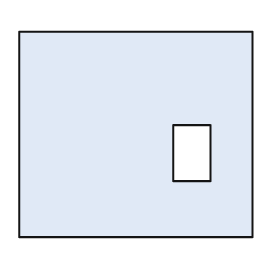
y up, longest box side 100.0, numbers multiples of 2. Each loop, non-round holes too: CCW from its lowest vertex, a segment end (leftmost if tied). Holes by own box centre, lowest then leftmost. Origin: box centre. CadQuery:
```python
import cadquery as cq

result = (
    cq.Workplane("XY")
    .moveTo(-50.0, -44.0)
    .lineTo(50.0, -44.0)
    .lineTo(50.0, 44.0)
    .lineTo(-50.0, 44.0)
    .close()
    .moveTo(16.0, -20.0)
    .lineTo(32.0, -20.0)
    .lineTo(32.0, 4.0)
    .lineTo(16.0, 4.0)
    .close()
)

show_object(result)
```